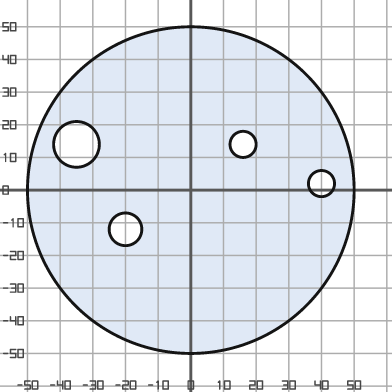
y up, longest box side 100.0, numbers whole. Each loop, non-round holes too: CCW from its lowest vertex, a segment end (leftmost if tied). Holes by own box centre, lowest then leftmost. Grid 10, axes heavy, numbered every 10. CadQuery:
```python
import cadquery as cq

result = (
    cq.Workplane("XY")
    .moveTo(0.0, 0.0)
    .circle(50.0)
    .moveTo(-20.0, -12.0)
    .circle(5.0)
    .moveTo(40.0, 2.0)
    .circle(4.0)
    .moveTo(-35.0, 14.0)
    .circle(7.0)
    .moveTo(16.0, 14.0)
    .circle(4.0)
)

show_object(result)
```